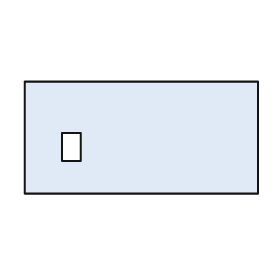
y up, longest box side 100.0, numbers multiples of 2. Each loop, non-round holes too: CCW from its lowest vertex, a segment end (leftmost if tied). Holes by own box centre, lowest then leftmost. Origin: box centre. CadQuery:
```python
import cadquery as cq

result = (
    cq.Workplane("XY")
    .moveTo(-50.0, -24.0)
    .lineTo(50.0, -24.0)
    .lineTo(50.0, 24.0)
    .lineTo(-50.0, 24.0)
    .close()
    .moveTo(-34.0, -10.0)
    .lineTo(-26.0, -10.0)
    .lineTo(-26.0, 2.0)
    .lineTo(-34.0, 2.0)
    .close()
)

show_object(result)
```